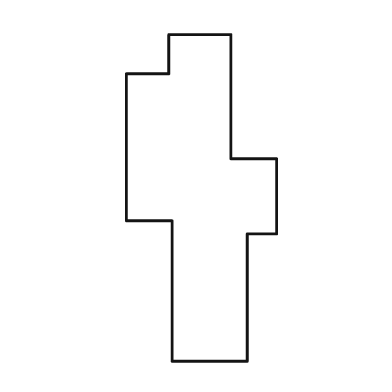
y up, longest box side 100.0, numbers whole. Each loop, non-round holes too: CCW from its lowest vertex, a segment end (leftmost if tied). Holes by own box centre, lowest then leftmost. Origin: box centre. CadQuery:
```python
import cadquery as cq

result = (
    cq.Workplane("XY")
    .moveTo(-9.0, -50.0)
    .lineTo(14.0, -50.0)
    .lineTo(14.0, -11.0)
    .lineTo(23.0, -11.0)
    .lineTo(23.0, 12.0)
    .lineTo(9.0, 12.0)
    .lineTo(9.0, 50.0)
    .lineTo(-10.0, 50.0)
    .lineTo(-10.0, 38.0)
    .lineTo(-23.0, 38.0)
    .lineTo(-23.0, -7.0)
    .lineTo(-9.0, -7.0)
    .close()
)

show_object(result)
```